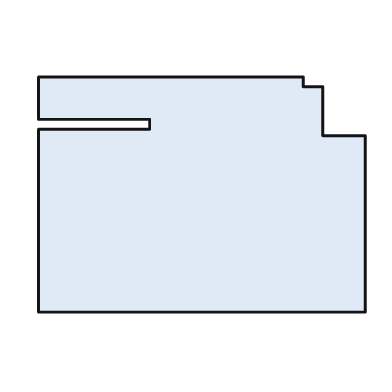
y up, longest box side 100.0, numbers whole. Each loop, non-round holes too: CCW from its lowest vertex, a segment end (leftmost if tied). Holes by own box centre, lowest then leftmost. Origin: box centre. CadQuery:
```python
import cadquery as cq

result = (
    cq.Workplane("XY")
    .moveTo(-50.0, -36.0)
    .lineTo(50.0, -36.0)
    .lineTo(50.0, 18.0)
    .lineTo(37.0, 18.0)
    .lineTo(37.0, 33.0)
    .lineTo(31.0, 33.0)
    .lineTo(31.0, 36.0)
    .lineTo(-50.0, 36.0)
    .lineTo(-50.0, 23.0)
    .lineTo(-16.0, 23.0)
    .lineTo(-16.0, 20.0)
    .lineTo(-50.0, 20.0)
    .close()
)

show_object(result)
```